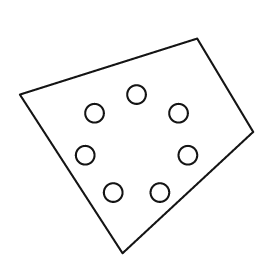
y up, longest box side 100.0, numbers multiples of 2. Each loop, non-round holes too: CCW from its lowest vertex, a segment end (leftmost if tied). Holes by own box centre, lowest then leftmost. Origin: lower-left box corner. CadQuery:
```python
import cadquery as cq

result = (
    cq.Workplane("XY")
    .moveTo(44.0, 0.0)
    .lineTo(100.0, 52.0)
    .lineTo(76.0, 92.0)
    .lineTo(0.0, 68.0)
    .close()
    .moveTo(40.0, 26.0)
    .circle(4.0)
    .moveTo(60.0, 26.0)
    .circle(4.0)
    .moveTo(28.0, 42.0)
    .circle(4.0)
    .moveTo(72.0, 42.0)
    .circle(4.0)
    .moveTo(32.0, 60.0)
    .circle(4.0)
    .moveTo(68.0, 60.0)
    .circle(4.0)
    .moveTo(50.0, 68.0)
    .circle(4.0)
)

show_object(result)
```